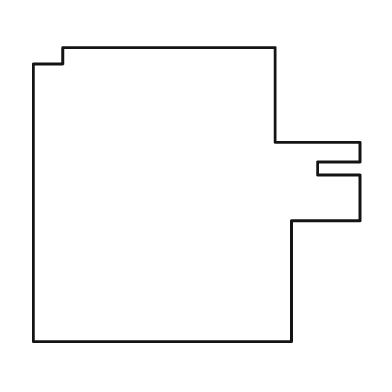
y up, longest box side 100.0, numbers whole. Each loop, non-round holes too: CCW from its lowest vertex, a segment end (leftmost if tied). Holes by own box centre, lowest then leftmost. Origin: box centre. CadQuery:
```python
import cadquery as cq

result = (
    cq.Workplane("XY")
    .moveTo(-50.0, -45.0)
    .lineTo(29.0, -45.0)
    .lineTo(29.0, -8.0)
    .lineTo(50.0, -8.0)
    .lineTo(50.0, 6.0)
    .lineTo(37.0, 6.0)
    .lineTo(37.0, 10.0)
    .lineTo(50.0, 10.0)
    .lineTo(50.0, 16.0)
    .lineTo(24.0, 16.0)
    .lineTo(24.0, 45.0)
    .lineTo(-41.0, 45.0)
    .lineTo(-41.0, 40.0)
    .lineTo(-50.0, 40.0)
    .close()
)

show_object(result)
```